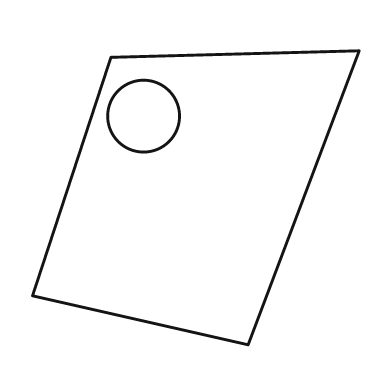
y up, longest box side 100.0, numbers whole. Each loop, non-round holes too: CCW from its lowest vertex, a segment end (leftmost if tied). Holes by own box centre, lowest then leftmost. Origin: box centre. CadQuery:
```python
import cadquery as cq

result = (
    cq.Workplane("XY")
    .moveTo(16.0, -45.0)
    .lineTo(50.0, 45.0)
    .lineTo(-26.0, 43.0)
    .lineTo(-50.0, -30.0)
    .close()
    .moveTo(-16.0, 25.0)
    .circle(11.0)
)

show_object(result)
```